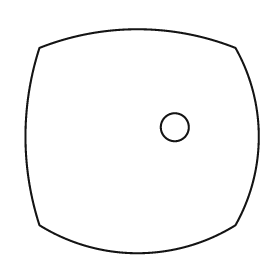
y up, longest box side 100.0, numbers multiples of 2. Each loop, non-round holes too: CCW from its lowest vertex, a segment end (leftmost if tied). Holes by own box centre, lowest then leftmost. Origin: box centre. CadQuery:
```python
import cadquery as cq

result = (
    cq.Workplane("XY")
    .moveTo(-44.0, -36.0)
    .threePointArc((-2.0, -48.0), (40.0, -36.0))
    .threePointArc((50.0, 2.0), (40.0, 40.0))
    .threePointArc((-2.0, 48.0), (-44.0, 40.0))
    .threePointArc((-50.0, 2.0), (-44.0, -36.0))
    .close()
    .moveTo(14.0, 6.0)
    .circle(6.0)
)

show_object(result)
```